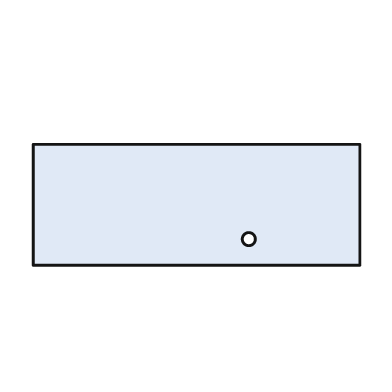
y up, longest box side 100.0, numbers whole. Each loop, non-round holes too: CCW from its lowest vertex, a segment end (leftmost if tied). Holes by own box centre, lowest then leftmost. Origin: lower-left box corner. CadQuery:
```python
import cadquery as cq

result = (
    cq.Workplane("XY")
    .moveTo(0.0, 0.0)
    .lineTo(100.0, 0.0)
    .lineTo(100.0, 37.0)
    .lineTo(0.0, 37.0)
    .close()
    .moveTo(66.0, 8.0)
    .circle(2.0)
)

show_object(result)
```